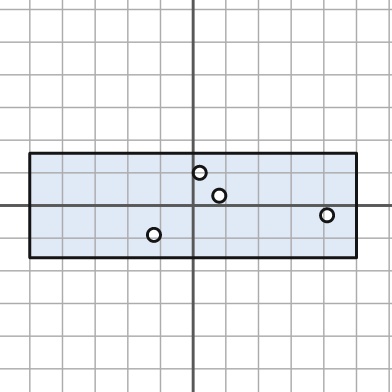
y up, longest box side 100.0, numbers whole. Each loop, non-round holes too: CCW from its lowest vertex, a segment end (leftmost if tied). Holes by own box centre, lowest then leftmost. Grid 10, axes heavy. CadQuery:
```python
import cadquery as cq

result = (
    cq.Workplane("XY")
    .moveTo(-50.0, -16.0)
    .lineTo(50.0, -16.0)
    .lineTo(50.0, 16.0)
    .lineTo(-50.0, 16.0)
    .close()
    .moveTo(-12.0, -9.0)
    .circle(2.0)
    .moveTo(41.0, -3.0)
    .circle(2.0)
    .moveTo(8.0, 3.0)
    .circle(2.0)
    .moveTo(2.0, 10.0)
    .circle(2.0)
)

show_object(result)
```